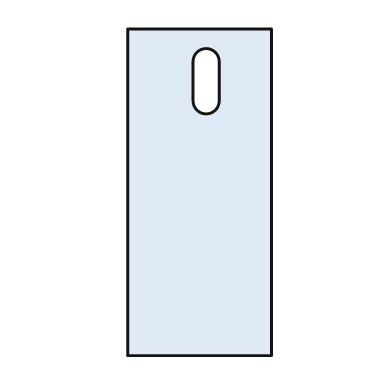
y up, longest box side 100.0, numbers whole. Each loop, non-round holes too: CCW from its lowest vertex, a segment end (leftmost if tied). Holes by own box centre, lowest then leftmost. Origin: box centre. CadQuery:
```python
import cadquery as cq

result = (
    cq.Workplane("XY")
    .moveTo(-22.0, -50.0)
    .lineTo(22.0, -50.0)
    .lineTo(22.0, 50.0)
    .lineTo(-22.0, 50.0)
    .close()
    .moveTo(-2.0, 28.0)
    .threePointArc((2.0, 24.0), (6.0, 28.0))
    .lineTo(6.0, 40.0)
    .threePointArc((2.0, 44.0), (-2.0, 40.0))
    .close()
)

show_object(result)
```